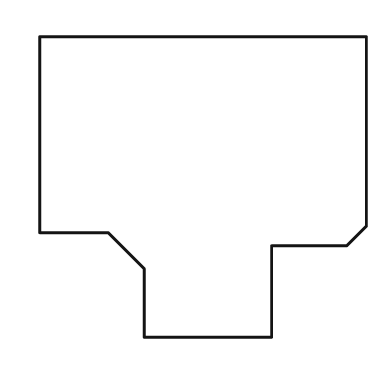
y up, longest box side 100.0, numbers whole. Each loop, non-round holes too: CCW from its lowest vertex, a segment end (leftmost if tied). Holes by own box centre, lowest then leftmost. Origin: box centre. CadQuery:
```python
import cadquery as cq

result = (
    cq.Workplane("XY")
    .moveTo(-18.0, -46.0)
    .lineTo(21.0, -46.0)
    .lineTo(21.0, -18.0)
    .lineTo(44.0, -18.0)
    .lineTo(50.0, -12.0)
    .lineTo(50.0, 46.0)
    .lineTo(-50.0, 46.0)
    .lineTo(-50.0, -14.0)
    .lineTo(-29.0, -14.0)
    .lineTo(-18.0, -25.0)
    .close()
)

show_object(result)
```